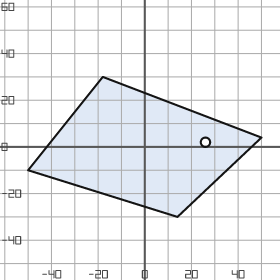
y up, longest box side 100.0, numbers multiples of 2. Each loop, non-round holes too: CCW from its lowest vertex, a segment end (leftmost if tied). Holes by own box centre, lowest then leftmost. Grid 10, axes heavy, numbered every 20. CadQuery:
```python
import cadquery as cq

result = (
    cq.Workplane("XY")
    .moveTo(14.0, -30.0)
    .lineTo(50.0, 4.0)
    .lineTo(-18.0, 30.0)
    .lineTo(-50.0, -10.0)
    .close()
    .moveTo(26.0, 2.0)
    .circle(2.0)
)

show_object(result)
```